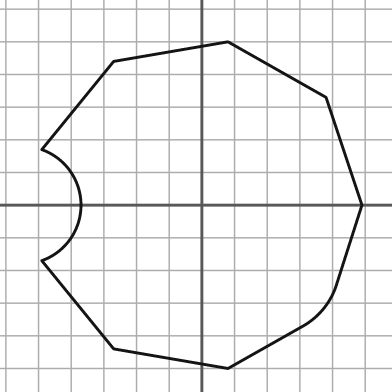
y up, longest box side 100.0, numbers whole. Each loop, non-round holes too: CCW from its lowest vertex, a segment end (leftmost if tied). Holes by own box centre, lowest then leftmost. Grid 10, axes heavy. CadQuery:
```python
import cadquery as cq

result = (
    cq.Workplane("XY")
    .moveTo(8.0, -50.0)
    .lineTo(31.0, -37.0)
    .threePointArc((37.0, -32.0), (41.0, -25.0))
    .lineTo(49.0, 0.0)
    .lineTo(38.0, 33.0)
    .lineTo(8.0, 50.0)
    .lineTo(-27.0, 44.0)
    .lineTo(-49.0, 17.0)
    .threePointArc((-37.0, 0.0), (-49.0, -17.0))
    .lineTo(-27.0, -44.0)
    .close()
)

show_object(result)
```